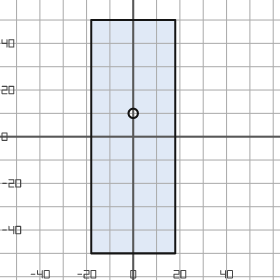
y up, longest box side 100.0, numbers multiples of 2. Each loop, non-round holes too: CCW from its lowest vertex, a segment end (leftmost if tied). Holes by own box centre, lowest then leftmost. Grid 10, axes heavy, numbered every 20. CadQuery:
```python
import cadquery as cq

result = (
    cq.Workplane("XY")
    .moveTo(-18.0, -50.0)
    .lineTo(18.0, -50.0)
    .lineTo(18.0, 50.0)
    .lineTo(-18.0, 50.0)
    .close()
    .moveTo(0.0, 10.0)
    .circle(2.0)
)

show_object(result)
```